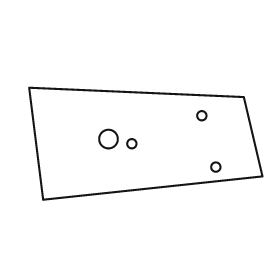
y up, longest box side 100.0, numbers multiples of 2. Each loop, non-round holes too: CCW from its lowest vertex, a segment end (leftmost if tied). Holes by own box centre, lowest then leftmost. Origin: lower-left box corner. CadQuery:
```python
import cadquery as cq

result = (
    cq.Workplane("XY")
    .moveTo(6.0, 0.0)
    .lineTo(100.0, 10.0)
    .lineTo(92.0, 44.0)
    .lineTo(0.0, 48.0)
    .close()
    .moveTo(80.0, 14.0)
    .circle(2.0)
    .moveTo(44.0, 24.0)
    .circle(2.0)
    .moveTo(34.0, 26.0)
    .circle(4.0)
    .moveTo(74.0, 36.0)
    .circle(2.0)
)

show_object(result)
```